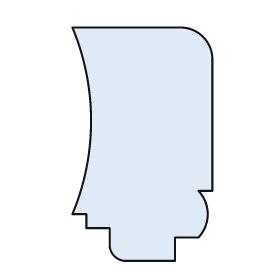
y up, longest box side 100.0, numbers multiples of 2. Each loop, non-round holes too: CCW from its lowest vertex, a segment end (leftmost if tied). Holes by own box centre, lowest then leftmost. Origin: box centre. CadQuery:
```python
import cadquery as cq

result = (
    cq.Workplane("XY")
    .moveTo(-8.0, -50.0)
    .lineTo(14.0, -50.0)
    .lineTo(14.0, -40.0)
    .lineTo(24.0, -40.0)
    .threePointArc((28.0, -30.0), (24.0, -20.0))
    .lineTo(30.0, -20.0)
    .lineTo(30.0, 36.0)
    .threePointArc((26.0, 46.0), (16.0, 50.0))
    .lineTo(-30.0, 50.0)
    .threePointArc((-22.0, 10.0), (-30.0, -30.0))
    .lineTo(-24.0, -30.0)
    .lineTo(-24.0, -36.0)
    .lineTo(-14.0, -36.0)
    .lineTo(-14.0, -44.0)
    .threePointArc((-12.0, -48.0), (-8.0, -50.0))
    .close()
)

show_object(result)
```